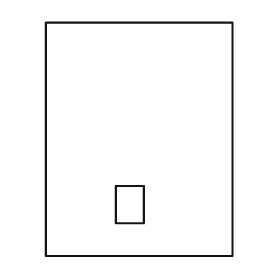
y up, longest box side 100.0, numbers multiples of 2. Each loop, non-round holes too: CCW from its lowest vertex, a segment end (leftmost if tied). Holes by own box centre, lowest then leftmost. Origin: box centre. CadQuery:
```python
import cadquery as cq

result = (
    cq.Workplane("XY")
    .moveTo(-40.0, -50.0)
    .lineTo(40.0, -50.0)
    .lineTo(40.0, 50.0)
    .lineTo(-40.0, 50.0)
    .close()
    .moveTo(-10.0, -36.0)
    .lineTo(2.0, -36.0)
    .lineTo(2.0, -20.0)
    .lineTo(-10.0, -20.0)
    .close()
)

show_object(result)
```